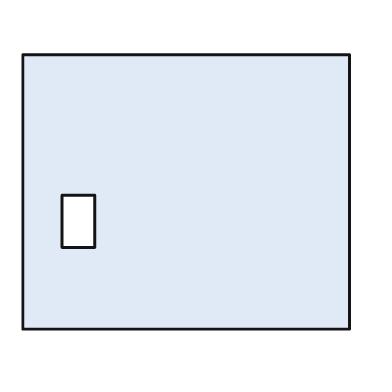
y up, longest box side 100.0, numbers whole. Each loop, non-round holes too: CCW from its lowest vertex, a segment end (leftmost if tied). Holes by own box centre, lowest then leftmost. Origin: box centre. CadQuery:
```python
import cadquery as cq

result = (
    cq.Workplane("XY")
    .moveTo(-50.0, -42.0)
    .lineTo(50.0, -42.0)
    .lineTo(50.0, 42.0)
    .lineTo(-50.0, 42.0)
    .close()
    .moveTo(-38.0, -17.0)
    .lineTo(-28.0, -17.0)
    .lineTo(-28.0, -1.0)
    .lineTo(-38.0, -1.0)
    .close()
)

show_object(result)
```